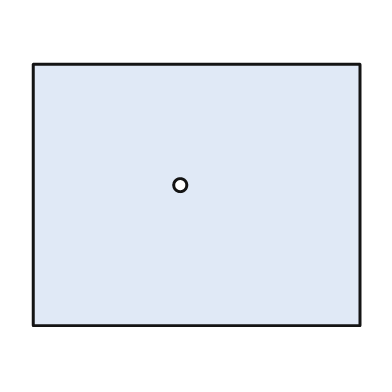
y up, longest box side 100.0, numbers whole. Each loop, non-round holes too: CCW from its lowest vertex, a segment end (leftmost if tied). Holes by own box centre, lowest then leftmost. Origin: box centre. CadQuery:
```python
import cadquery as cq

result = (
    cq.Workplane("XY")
    .moveTo(-50.0, -40.0)
    .lineTo(50.0, -40.0)
    .lineTo(50.0, 40.0)
    .lineTo(-50.0, 40.0)
    .close()
    .moveTo(-5.0, 3.0)
    .circle(2.0)
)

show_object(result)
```